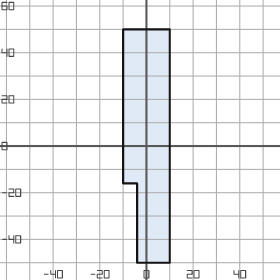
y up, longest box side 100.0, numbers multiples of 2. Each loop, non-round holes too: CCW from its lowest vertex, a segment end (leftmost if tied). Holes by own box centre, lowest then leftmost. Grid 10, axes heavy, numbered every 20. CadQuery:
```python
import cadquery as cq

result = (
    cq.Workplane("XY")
    .moveTo(-4.0, -50.0)
    .lineTo(10.0, -50.0)
    .lineTo(10.0, 50.0)
    .lineTo(-10.0, 50.0)
    .lineTo(-10.0, -16.0)
    .lineTo(-4.0, -16.0)
    .close()
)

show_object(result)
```